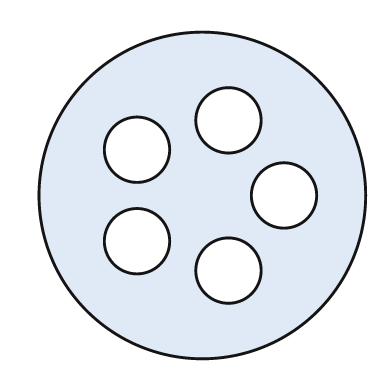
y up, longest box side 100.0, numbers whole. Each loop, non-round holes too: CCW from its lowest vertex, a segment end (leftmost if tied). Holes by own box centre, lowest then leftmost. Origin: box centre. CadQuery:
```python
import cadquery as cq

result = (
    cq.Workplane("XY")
    .moveTo(0.0, 0.0)
    .circle(50.0)
    .moveTo(8.0, -23.0)
    .circle(10.0)
    .moveTo(-20.0, -14.0)
    .circle(10.0)
    .moveTo(25.0, 0.0)
    .circle(10.0)
    .moveTo(-20.0, 14.0)
    .circle(10.0)
    .moveTo(8.0, 23.0)
    .circle(10.0)
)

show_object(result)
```